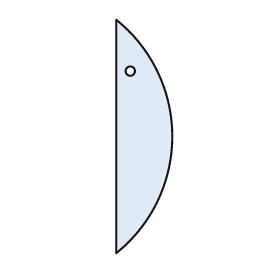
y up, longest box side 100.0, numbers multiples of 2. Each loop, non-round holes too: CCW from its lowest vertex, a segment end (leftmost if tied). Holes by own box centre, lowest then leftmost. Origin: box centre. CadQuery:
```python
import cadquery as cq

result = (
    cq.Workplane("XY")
    .moveTo(-12.0, -50.0)
    .threePointArc((12.0, 0.0), (-12.0, 50.0))
    .close()
    .moveTo(-6.0, 28.0)
    .circle(2.0)
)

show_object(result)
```